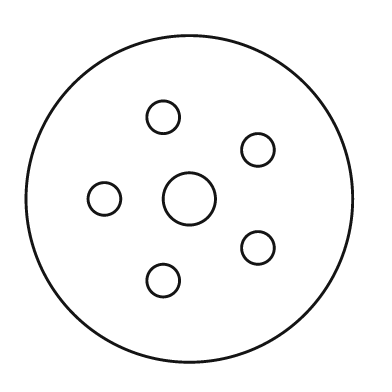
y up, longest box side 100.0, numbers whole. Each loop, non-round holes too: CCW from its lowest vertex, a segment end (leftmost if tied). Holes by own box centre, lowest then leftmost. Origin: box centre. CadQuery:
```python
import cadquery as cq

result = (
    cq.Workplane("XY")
    .moveTo(0.0, 0.0)
    .circle(50.0)
    .moveTo(-8.0, -25.0)
    .circle(5.0)
    .moveTo(21.0, -15.0)
    .circle(5.0)
    .moveTo(-26.0, 0.0)
    .circle(5.0)
    .moveTo(0.0, 0.0)
    .circle(8.0)
    .moveTo(21.0, 15.0)
    .circle(5.0)
    .moveTo(-8.0, 25.0)
    .circle(5.0)
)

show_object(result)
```